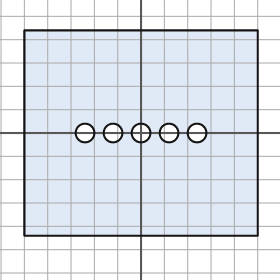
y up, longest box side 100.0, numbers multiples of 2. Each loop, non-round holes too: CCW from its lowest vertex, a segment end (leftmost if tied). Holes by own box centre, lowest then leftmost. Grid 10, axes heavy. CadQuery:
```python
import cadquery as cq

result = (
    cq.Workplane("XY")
    .moveTo(-50.0, -44.0)
    .lineTo(50.0, -44.0)
    .lineTo(50.0, 44.0)
    .lineTo(-50.0, 44.0)
    .close()
    .moveTo(-24.0, 0.0)
    .circle(4.0)
    .moveTo(-12.0, 0.0)
    .circle(4.0)
    .moveTo(0.0, 0.0)
    .circle(4.0)
    .moveTo(12.0, 0.0)
    .circle(4.0)
    .moveTo(24.0, 0.0)
    .circle(4.0)
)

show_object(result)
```